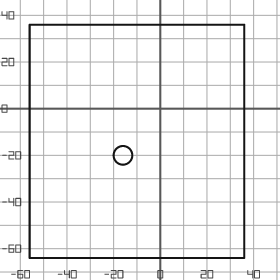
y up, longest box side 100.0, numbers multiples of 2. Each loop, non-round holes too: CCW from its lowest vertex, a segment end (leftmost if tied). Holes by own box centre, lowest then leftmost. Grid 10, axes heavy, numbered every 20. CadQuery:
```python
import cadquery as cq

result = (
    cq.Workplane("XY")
    .moveTo(-56.0, -64.0)
    .lineTo(36.0, -64.0)
    .lineTo(36.0, 36.0)
    .lineTo(-56.0, 36.0)
    .close()
    .moveTo(-16.0, -20.0)
    .circle(4.0)
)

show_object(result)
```